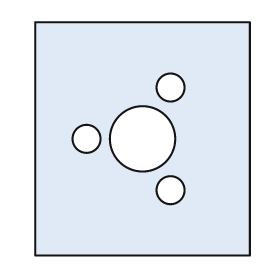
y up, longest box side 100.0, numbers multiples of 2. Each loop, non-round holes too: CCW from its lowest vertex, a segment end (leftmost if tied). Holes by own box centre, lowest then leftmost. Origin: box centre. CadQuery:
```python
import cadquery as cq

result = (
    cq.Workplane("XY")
    .moveTo(-46.0, -50.0)
    .lineTo(46.0, -50.0)
    .lineTo(46.0, 50.0)
    .lineTo(-46.0, 50.0)
    .close()
    .moveTo(12.0, -22.0)
    .circle(6.0)
    .moveTo(-24.0, 0.0)
    .circle(6.0)
    .moveTo(0.0, 0.0)
    .circle(14.0)
    .moveTo(12.0, 22.0)
    .circle(6.0)
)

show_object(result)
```